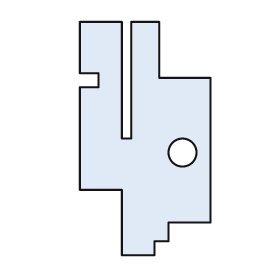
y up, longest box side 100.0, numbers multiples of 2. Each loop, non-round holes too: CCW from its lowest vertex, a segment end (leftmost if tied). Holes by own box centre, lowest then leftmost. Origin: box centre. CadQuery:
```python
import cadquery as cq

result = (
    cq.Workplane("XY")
    .moveTo(-10.0, -50.0)
    .lineTo(4.0, -50.0)
    .lineTo(4.0, -44.0)
    .lineTo(10.0, -44.0)
    .lineTo(10.0, -36.0)
    .lineTo(28.0, -36.0)
    .lineTo(28.0, 26.0)
    .lineTo(6.0, 26.0)
    .lineTo(6.0, 50.0)
    .lineTo(-6.0, 50.0)
    .lineTo(-6.0, 0.0)
    .lineTo(-10.0, 0.0)
    .lineTo(-10.0, 50.0)
    .lineTo(-28.0, 50.0)
    .lineTo(-28.0, 28.0)
    .lineTo(-20.0, 28.0)
    .lineTo(-20.0, 22.0)
    .lineTo(-28.0, 22.0)
    .lineTo(-28.0, -22.0)
    .lineTo(-10.0, -22.0)
    .close()
    .moveTo(16.0, -6.0)
    .circle(6.0)
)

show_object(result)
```